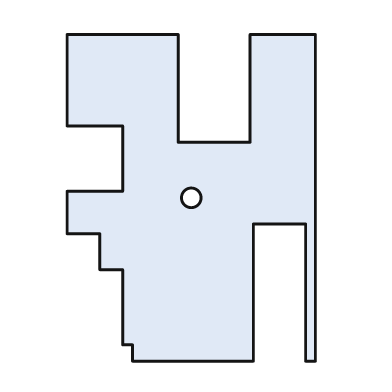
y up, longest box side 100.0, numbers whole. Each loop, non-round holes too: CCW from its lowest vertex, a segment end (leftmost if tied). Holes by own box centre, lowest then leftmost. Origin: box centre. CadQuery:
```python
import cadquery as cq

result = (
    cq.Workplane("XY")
    .moveTo(-18.0, -50.0)
    .lineTo(19.0, -50.0)
    .lineTo(19.0, -8.0)
    .lineTo(35.0, -8.0)
    .lineTo(35.0, -50.0)
    .lineTo(38.0, -50.0)
    .lineTo(38.0, 50.0)
    .lineTo(18.0, 50.0)
    .lineTo(18.0, 17.0)
    .lineTo(-4.0, 17.0)
    .lineTo(-4.0, 50.0)
    .lineTo(-38.0, 50.0)
    .lineTo(-38.0, 22.0)
    .lineTo(-21.0, 22.0)
    .lineTo(-21.0, 2.0)
    .lineTo(-38.0, 2.0)
    .lineTo(-38.0, -11.0)
    .lineTo(-28.0, -11.0)
    .lineTo(-28.0, -22.0)
    .lineTo(-21.0, -22.0)
    .lineTo(-21.0, -45.0)
    .lineTo(-18.0, -45.0)
    .close()
    .moveTo(0.0, 0.0)
    .circle(3.0)
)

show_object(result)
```